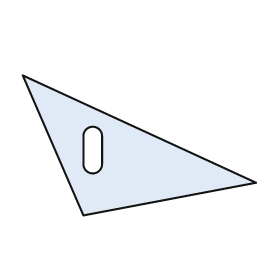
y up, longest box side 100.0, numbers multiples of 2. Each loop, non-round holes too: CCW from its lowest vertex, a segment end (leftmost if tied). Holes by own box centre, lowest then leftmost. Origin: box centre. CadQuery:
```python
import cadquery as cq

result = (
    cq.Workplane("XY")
    .moveTo(-24.0, -30.0)
    .lineTo(50.0, -16.0)
    .lineTo(-50.0, 30.0)
    .close()
    .moveTo(-24.0, -8.0)
    .threePointArc((-20.0, -12.0), (-16.0, -8.0))
    .lineTo(-16.0, 4.0)
    .threePointArc((-20.0, 8.0), (-24.0, 4.0))
    .close()
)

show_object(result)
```